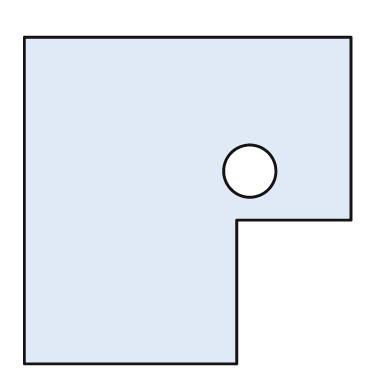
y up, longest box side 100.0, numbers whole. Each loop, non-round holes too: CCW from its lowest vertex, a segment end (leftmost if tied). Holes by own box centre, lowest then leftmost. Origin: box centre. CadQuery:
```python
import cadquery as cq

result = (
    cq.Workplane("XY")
    .moveTo(-50.0, -50.0)
    .lineTo(15.0, -50.0)
    .lineTo(15.0, -6.0)
    .lineTo(50.0, -6.0)
    .lineTo(50.0, 50.0)
    .lineTo(-50.0, 50.0)
    .close()
    .moveTo(19.0, 9.0)
    .circle(8.0)
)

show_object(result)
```